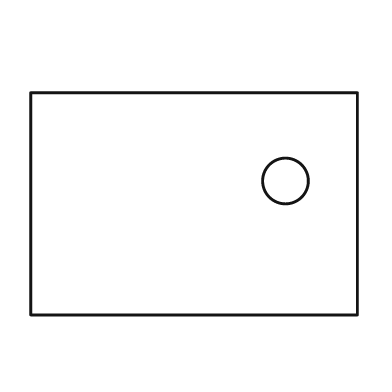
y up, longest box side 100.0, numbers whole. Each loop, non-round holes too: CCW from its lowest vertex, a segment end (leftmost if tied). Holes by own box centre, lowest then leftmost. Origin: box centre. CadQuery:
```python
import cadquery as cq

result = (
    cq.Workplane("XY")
    .moveTo(-50.0, -34.0)
    .lineTo(50.0, -34.0)
    .lineTo(50.0, 34.0)
    .lineTo(-50.0, 34.0)
    .close()
    .moveTo(28.0, 7.0)
    .circle(7.0)
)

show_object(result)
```